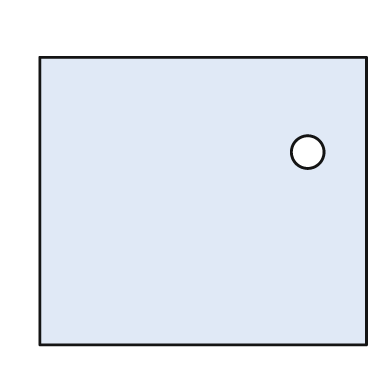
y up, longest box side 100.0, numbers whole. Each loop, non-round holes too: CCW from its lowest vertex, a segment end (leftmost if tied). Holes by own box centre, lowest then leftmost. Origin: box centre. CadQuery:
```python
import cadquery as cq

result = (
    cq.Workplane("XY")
    .moveTo(-50.0, -44.0)
    .lineTo(50.0, -44.0)
    .lineTo(50.0, 44.0)
    .lineTo(-50.0, 44.0)
    .close()
    .moveTo(32.0, 15.0)
    .circle(5.0)
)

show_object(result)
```